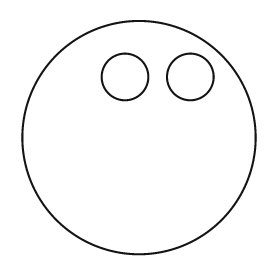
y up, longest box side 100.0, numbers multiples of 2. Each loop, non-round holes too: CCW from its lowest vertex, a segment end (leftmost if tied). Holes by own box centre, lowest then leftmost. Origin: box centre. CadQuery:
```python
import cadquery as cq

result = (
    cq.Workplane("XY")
    .moveTo(0.0, 0.0)
    .circle(50.0)
    .moveTo(-6.0, 26.0)
    .circle(10.0)
    .moveTo(22.0, 26.0)
    .circle(10.0)
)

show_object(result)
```